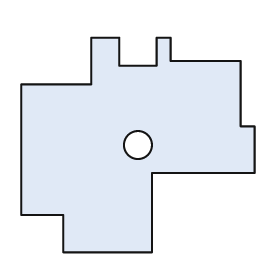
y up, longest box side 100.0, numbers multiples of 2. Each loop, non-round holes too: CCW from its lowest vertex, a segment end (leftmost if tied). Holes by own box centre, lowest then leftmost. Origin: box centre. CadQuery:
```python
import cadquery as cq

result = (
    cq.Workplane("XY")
    .moveTo(-32.0, -46.0)
    .lineTo(6.0, -46.0)
    .lineTo(6.0, -12.0)
    .lineTo(50.0, -12.0)
    .lineTo(50.0, 8.0)
    .lineTo(44.0, 8.0)
    .lineTo(44.0, 36.0)
    .lineTo(14.0, 36.0)
    .lineTo(14.0, 46.0)
    .lineTo(8.0, 46.0)
    .lineTo(8.0, 34.0)
    .lineTo(-8.0, 34.0)
    .lineTo(-8.0, 46.0)
    .lineTo(-20.0, 46.0)
    .lineTo(-20.0, 26.0)
    .lineTo(-50.0, 26.0)
    .lineTo(-50.0, -30.0)
    .lineTo(-32.0, -30.0)
    .close()
    .moveTo(0.0, 0.0)
    .circle(6.0)
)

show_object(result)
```